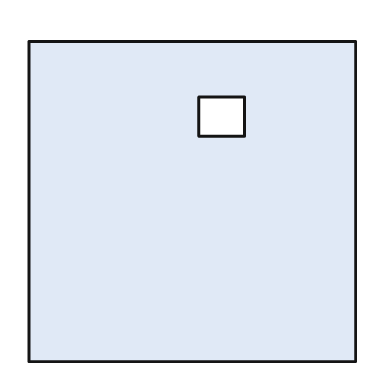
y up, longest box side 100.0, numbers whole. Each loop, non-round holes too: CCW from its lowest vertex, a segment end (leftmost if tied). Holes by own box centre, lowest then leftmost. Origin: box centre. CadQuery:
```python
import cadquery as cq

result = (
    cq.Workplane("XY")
    .moveTo(-50.0, -49.0)
    .lineTo(50.0, -49.0)
    .lineTo(50.0, 49.0)
    .lineTo(-50.0, 49.0)
    .close()
    .moveTo(2.0, 20.0)
    .lineTo(16.0, 20.0)
    .lineTo(16.0, 32.0)
    .lineTo(2.0, 32.0)
    .close()
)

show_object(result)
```